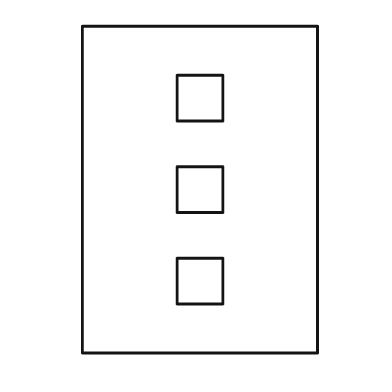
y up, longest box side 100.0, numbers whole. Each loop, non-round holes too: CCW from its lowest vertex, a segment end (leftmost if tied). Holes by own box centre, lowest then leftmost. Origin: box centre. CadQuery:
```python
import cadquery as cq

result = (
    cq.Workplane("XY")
    .moveTo(-36.0, -50.0)
    .lineTo(36.0, -50.0)
    .lineTo(36.0, 50.0)
    .lineTo(-36.0, 50.0)
    .close()
    .moveTo(-7.0, -35.0)
    .lineTo(7.0, -35.0)
    .lineTo(7.0, -21.0)
    .lineTo(-7.0, -21.0)
    .close()
    .moveTo(-7.0, -7.0)
    .lineTo(7.0, -7.0)
    .lineTo(7.0, 7.0)
    .lineTo(-7.0, 7.0)
    .close()
    .moveTo(-7.0, 21.0)
    .lineTo(7.0, 21.0)
    .lineTo(7.0, 35.0)
    .lineTo(-7.0, 35.0)
    .close()
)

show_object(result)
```